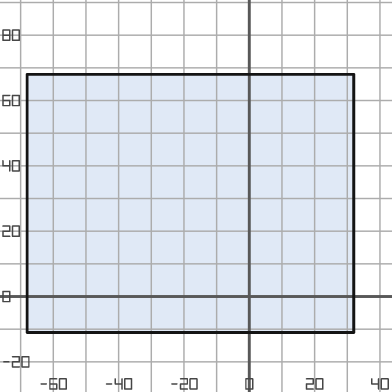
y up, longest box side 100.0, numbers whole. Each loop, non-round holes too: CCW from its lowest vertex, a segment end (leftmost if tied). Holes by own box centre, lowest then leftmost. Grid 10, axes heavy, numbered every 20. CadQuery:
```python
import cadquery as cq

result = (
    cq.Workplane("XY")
    .moveTo(-68.0, -11.0)
    .lineTo(32.0, -11.0)
    .lineTo(32.0, 68.0)
    .lineTo(-68.0, 68.0)
    .close()
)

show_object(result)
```